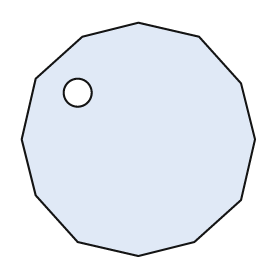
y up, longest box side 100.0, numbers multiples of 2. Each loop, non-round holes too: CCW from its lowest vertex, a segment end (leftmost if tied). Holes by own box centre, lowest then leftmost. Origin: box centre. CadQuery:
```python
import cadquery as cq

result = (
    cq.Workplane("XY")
    .moveTo(0.0, -50.0)
    .lineTo(24.0, -44.0)
    .lineTo(44.0, -26.0)
    .lineTo(50.0, 0.0)
    .lineTo(44.0, 24.0)
    .lineTo(26.0, 44.0)
    .lineTo(0.0, 50.0)
    .lineTo(-24.0, 44.0)
    .lineTo(-44.0, 26.0)
    .lineTo(-50.0, 0.0)
    .lineTo(-44.0, -24.0)
    .lineTo(-26.0, -44.0)
    .close()
    .moveTo(-26.0, 20.0)
    .circle(6.0)
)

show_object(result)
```